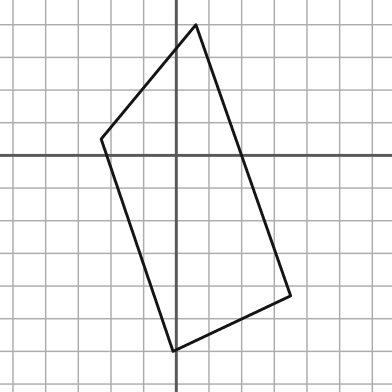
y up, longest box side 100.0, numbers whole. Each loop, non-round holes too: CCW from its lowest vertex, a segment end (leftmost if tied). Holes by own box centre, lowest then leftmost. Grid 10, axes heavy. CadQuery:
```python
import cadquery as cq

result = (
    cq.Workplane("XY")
    .moveTo(-1.0, -60.0)
    .lineTo(35.0, -43.0)
    .lineTo(6.0, 40.0)
    .lineTo(-23.0, 5.0)
    .close()
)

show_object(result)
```